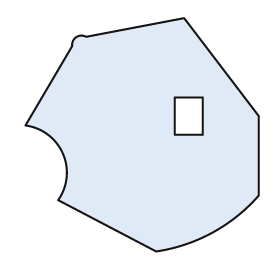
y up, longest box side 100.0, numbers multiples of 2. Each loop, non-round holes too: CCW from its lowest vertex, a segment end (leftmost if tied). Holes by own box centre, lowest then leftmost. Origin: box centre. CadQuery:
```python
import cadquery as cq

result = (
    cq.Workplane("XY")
    .moveTo(6.0, -50.0)
    .threePointArc((30.0, -42.0), (50.0, -26.0))
    .lineTo(50.0, 8.0)
    .lineTo(18.0, 50.0)
    .lineTo(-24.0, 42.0)
    .threePointArc((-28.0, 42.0), (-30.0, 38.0))
    .lineTo(-50.0, 4.0)
    .threePointArc((-34.0, -8.0), (-36.0, -28.0))
    .close()
    .moveTo(14.0, 0.0)
    .lineTo(26.0, 0.0)
    .lineTo(26.0, 16.0)
    .lineTo(14.0, 16.0)
    .close()
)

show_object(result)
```